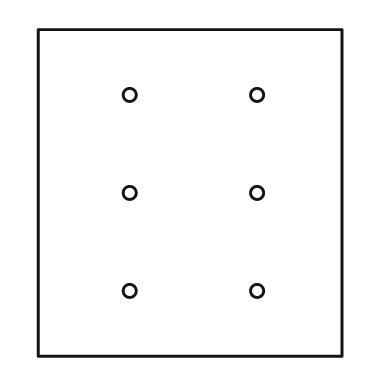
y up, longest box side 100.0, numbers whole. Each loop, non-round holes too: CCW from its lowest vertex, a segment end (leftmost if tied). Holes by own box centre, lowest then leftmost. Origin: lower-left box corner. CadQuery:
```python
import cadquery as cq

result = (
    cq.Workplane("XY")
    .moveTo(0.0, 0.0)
    .lineTo(93.0, 0.0)
    .lineTo(93.0, 100.0)
    .lineTo(0.0, 100.0)
    .close()
    .moveTo(28.0, 20.0)
    .circle(2.0)
    .moveTo(67.0, 20.0)
    .circle(2.0)
    .moveTo(28.0, 50.0)
    .circle(2.0)
    .moveTo(67.0, 50.0)
    .circle(2.0)
    .moveTo(28.0, 80.0)
    .circle(2.0)
    .moveTo(67.0, 80.0)
    .circle(2.0)
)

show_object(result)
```